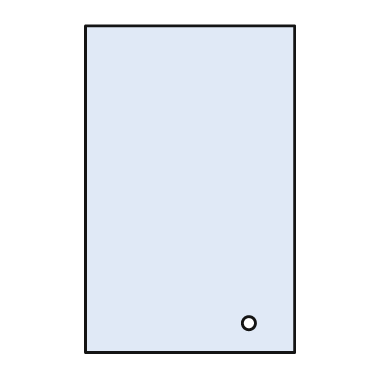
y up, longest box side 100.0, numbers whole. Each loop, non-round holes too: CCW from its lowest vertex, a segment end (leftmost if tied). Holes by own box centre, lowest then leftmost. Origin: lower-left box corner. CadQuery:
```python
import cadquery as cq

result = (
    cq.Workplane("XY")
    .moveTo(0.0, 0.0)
    .lineTo(64.0, 0.0)
    .lineTo(64.0, 100.0)
    .lineTo(0.0, 100.0)
    .close()
    .moveTo(50.0, 9.0)
    .circle(2.0)
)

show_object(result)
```